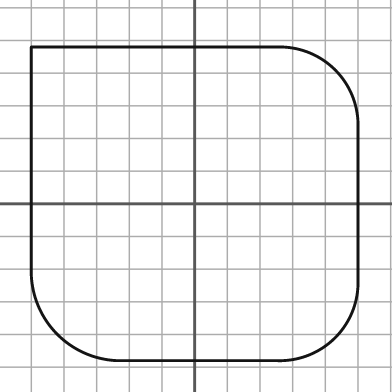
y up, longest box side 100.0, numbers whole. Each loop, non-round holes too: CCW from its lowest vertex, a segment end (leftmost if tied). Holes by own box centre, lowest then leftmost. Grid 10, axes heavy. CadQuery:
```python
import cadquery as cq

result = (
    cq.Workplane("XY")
    .moveTo(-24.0, -48.0)
    .lineTo(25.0, -48.0)
    .threePointArc((43.0, -41.0), (50.0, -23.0))
    .lineTo(50.0, 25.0)
    .threePointArc((43.0, 41.0), (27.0, 48.0))
    .lineTo(-50.0, 48.0)
    .lineTo(-50.0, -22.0)
    .threePointArc((-42.0, -40.0), (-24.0, -48.0))
    .close()
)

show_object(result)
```